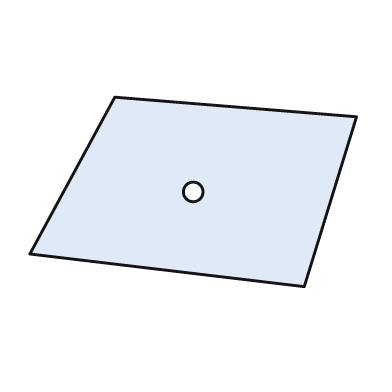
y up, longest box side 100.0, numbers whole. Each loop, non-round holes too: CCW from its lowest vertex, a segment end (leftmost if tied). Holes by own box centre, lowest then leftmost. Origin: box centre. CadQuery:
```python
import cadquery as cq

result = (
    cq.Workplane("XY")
    .moveTo(34.0, -29.0)
    .lineTo(50.0, 23.0)
    .lineTo(-24.0, 29.0)
    .lineTo(-50.0, -19.0)
    .close()
    .moveTo(0.0, 0.0)
    .circle(3.0)
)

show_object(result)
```